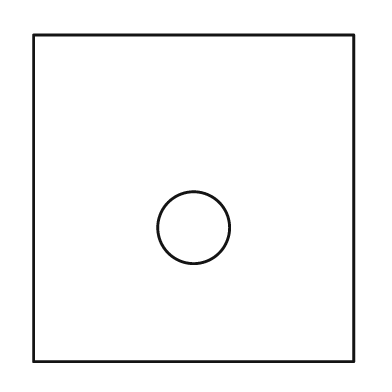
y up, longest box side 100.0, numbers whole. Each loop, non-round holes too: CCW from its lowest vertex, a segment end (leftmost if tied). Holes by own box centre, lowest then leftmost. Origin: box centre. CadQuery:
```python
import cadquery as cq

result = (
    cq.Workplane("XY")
    .moveTo(-49.0, -50.0)
    .lineTo(49.0, -50.0)
    .lineTo(49.0, 50.0)
    .lineTo(-49.0, 50.0)
    .close()
    .moveTo(0.0, -9.0)
    .circle(11.0)
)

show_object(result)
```